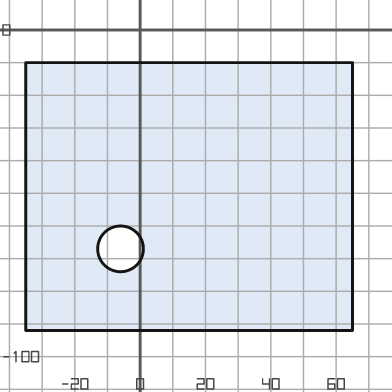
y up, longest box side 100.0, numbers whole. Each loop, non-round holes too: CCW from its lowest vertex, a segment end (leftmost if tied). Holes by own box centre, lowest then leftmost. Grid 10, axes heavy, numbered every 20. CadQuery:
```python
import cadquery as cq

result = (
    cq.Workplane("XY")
    .moveTo(-35.0, -92.0)
    .lineTo(65.0, -92.0)
    .lineTo(65.0, -10.0)
    .lineTo(-35.0, -10.0)
    .close()
    .moveTo(-6.0, -67.0)
    .circle(7.0)
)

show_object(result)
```